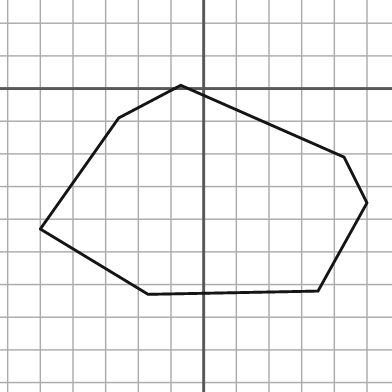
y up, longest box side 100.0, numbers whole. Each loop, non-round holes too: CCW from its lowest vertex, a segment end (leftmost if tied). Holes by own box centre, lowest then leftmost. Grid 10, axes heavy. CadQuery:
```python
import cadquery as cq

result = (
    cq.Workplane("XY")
    .moveTo(-17.0, -63.0)
    .lineTo(35.0, -62.0)
    .lineTo(50.0, -35.0)
    .lineTo(43.0, -21.0)
    .lineTo(-7.0, 1.0)
    .lineTo(-26.0, -9.0)
    .lineTo(-50.0, -43.0)
    .close()
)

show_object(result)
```